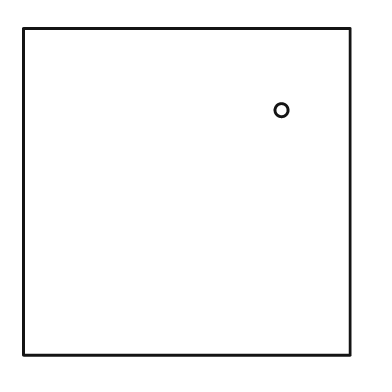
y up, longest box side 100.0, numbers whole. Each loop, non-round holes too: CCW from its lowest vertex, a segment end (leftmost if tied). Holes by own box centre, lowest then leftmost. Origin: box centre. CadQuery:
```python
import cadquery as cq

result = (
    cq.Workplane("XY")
    .moveTo(-50.0, -50.0)
    .lineTo(50.0, -50.0)
    .lineTo(50.0, 50.0)
    .lineTo(-50.0, 50.0)
    .close()
    .moveTo(29.0, 25.0)
    .circle(2.0)
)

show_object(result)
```